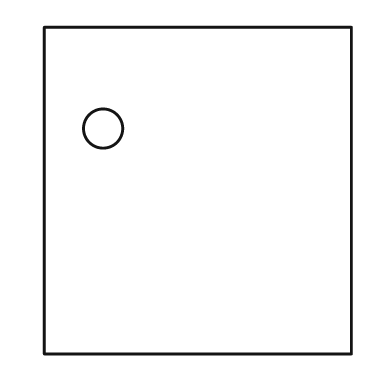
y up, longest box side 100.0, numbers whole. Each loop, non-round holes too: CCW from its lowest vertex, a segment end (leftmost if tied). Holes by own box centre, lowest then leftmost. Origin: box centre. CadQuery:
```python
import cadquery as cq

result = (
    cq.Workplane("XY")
    .moveTo(-47.0, -50.0)
    .lineTo(47.0, -50.0)
    .lineTo(47.0, 50.0)
    .lineTo(-47.0, 50.0)
    .close()
    .moveTo(-29.0, 19.0)
    .circle(6.0)
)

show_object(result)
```